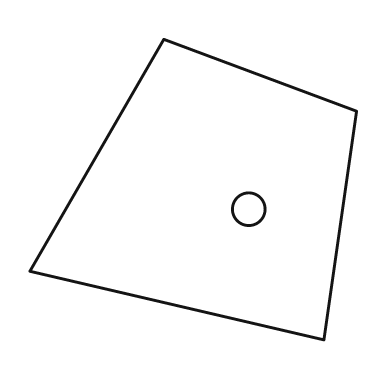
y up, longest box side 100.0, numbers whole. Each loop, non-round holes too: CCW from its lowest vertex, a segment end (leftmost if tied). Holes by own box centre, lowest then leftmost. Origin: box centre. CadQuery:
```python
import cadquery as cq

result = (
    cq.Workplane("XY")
    .moveTo(40.0, -46.0)
    .lineTo(50.0, 24.0)
    .lineTo(-9.0, 46.0)
    .lineTo(-50.0, -25.0)
    .close()
    .moveTo(17.0, -6.0)
    .circle(5.0)
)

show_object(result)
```